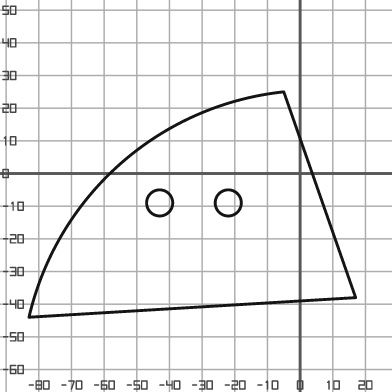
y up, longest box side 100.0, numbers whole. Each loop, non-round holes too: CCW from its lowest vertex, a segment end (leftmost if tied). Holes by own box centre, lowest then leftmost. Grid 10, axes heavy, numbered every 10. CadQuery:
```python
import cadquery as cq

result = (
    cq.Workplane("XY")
    .moveTo(-83.0, -44.0)
    .lineTo(17.0, -38.0)
    .lineTo(-5.0, 25.0)
    .threePointArc((-55.0, 3.0), (-83.0, -44.0))
    .close()
    .moveTo(-43.0, -9.0)
    .circle(4.0)
    .moveTo(-22.0, -9.0)
    .circle(4.0)
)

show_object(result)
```